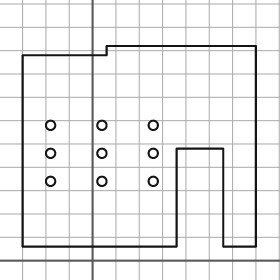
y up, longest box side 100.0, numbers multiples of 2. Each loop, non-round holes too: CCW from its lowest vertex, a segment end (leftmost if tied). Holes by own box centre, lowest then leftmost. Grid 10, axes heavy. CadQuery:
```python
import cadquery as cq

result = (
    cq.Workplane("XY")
    .moveTo(-30.0, 6.0)
    .lineTo(36.0, 6.0)
    .lineTo(36.0, 48.0)
    .lineTo(56.0, 48.0)
    .lineTo(56.0, 6.0)
    .lineTo(70.0, 6.0)
    .lineTo(70.0, 92.0)
    .lineTo(6.0, 92.0)
    .lineTo(6.0, 88.0)
    .lineTo(-30.0, 88.0)
    .close()
    .moveTo(-18.0, 34.0)
    .circle(2.0)
    .moveTo(4.0, 34.0)
    .circle(2.0)
    .moveTo(26.0, 34.0)
    .circle(2.0)
    .moveTo(-18.0, 46.0)
    .circle(2.0)
    .moveTo(4.0, 46.0)
    .circle(2.0)
    .moveTo(26.0, 46.0)
    .circle(2.0)
    .moveTo(-18.0, 58.0)
    .circle(2.0)
    .moveTo(4.0, 58.0)
    .circle(2.0)
    .moveTo(26.0, 58.0)
    .circle(2.0)
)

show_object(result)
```